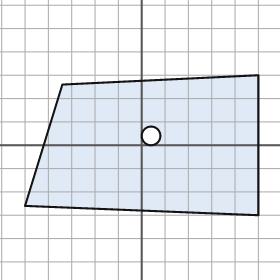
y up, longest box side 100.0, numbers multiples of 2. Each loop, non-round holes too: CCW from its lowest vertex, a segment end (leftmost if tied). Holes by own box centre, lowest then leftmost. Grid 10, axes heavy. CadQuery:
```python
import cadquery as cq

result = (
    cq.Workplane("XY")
    .moveTo(50.0, -30.0)
    .lineTo(50.0, 30.0)
    .lineTo(-34.0, 26.0)
    .lineTo(-50.0, -26.0)
    .close()
    .moveTo(4.0, 4.0)
    .circle(4.0)
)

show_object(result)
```